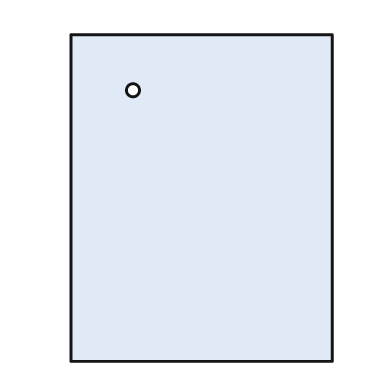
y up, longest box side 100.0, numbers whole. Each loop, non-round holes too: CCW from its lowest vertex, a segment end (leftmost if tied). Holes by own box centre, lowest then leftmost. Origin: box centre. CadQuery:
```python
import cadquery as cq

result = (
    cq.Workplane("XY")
    .moveTo(-40.0, -50.0)
    .lineTo(40.0, -50.0)
    .lineTo(40.0, 50.0)
    .lineTo(-40.0, 50.0)
    .close()
    .moveTo(-21.0, 33.0)
    .circle(2.0)
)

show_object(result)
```